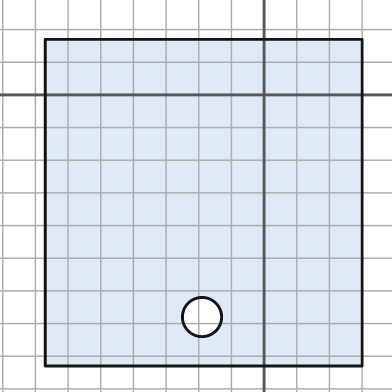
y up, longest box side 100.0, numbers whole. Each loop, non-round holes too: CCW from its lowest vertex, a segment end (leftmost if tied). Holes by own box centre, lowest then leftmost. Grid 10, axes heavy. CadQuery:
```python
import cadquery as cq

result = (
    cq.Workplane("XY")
    .moveTo(-67.0, -83.0)
    .lineTo(30.0, -83.0)
    .lineTo(30.0, 17.0)
    .lineTo(-67.0, 17.0)
    .close()
    .moveTo(-19.0, -68.0)
    .circle(6.0)
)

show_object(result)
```